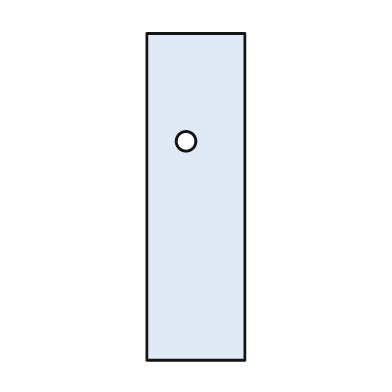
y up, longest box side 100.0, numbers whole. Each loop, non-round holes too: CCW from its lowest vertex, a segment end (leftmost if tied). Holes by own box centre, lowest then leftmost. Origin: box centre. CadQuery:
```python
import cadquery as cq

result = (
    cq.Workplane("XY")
    .moveTo(-15.0, -50.0)
    .lineTo(15.0, -50.0)
    .lineTo(15.0, 50.0)
    .lineTo(-15.0, 50.0)
    .close()
    .moveTo(-3.0, 17.0)
    .circle(3.0)
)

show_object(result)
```